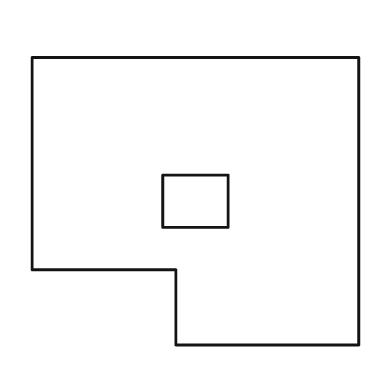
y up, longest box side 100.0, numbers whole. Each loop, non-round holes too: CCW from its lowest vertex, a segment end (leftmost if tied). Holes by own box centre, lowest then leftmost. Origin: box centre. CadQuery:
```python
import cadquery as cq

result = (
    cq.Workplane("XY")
    .moveTo(-6.0, -44.0)
    .lineTo(50.0, -44.0)
    .lineTo(50.0, 44.0)
    .lineTo(-50.0, 44.0)
    .lineTo(-50.0, -21.0)
    .lineTo(-6.0, -21.0)
    .close()
    .moveTo(-10.0, -8.0)
    .lineTo(10.0, -8.0)
    .lineTo(10.0, 8.0)
    .lineTo(-10.0, 8.0)
    .close()
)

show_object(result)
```